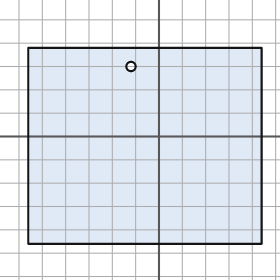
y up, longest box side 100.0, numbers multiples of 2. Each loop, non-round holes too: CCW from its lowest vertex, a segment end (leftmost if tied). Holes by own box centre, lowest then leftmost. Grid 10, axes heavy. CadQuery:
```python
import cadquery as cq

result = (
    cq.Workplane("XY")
    .moveTo(-56.0, -46.0)
    .lineTo(44.0, -46.0)
    .lineTo(44.0, 38.0)
    .lineTo(-56.0, 38.0)
    .close()
    .moveTo(-12.0, 30.0)
    .circle(2.0)
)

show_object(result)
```